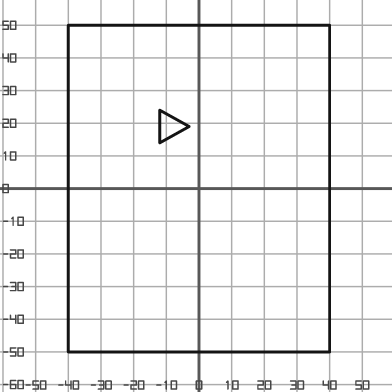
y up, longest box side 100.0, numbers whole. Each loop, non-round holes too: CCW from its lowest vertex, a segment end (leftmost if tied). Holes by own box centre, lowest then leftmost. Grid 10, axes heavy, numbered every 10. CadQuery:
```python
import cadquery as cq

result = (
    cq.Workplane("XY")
    .moveTo(-40.0, -50.0)
    .lineTo(40.0, -50.0)
    .lineTo(40.0, 50.0)
    .lineTo(-40.0, 50.0)
    .close()
    .moveTo(-12.0, 14.0)
    .lineTo(-3.0, 19.0)
    .lineTo(-12.0, 24.0)
    .close()
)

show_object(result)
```